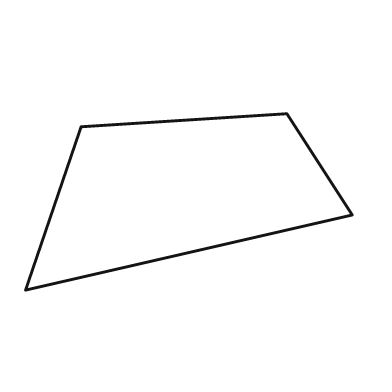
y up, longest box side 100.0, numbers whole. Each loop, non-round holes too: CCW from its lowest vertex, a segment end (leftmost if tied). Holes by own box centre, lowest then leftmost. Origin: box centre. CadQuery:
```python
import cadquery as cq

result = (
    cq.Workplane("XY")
    .moveTo(-50.0, -27.0)
    .lineTo(50.0, -4.0)
    .lineTo(30.0, 27.0)
    .lineTo(-33.0, 23.0)
    .close()
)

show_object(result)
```